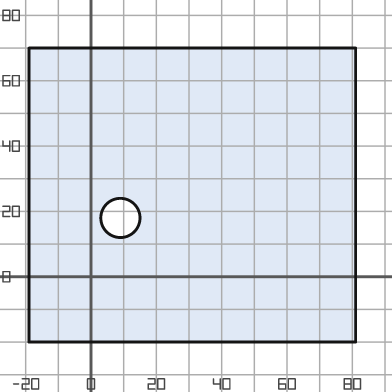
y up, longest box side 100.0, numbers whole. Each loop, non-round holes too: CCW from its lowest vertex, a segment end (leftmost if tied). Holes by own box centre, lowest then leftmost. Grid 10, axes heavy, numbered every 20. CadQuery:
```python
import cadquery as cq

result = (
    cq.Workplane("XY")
    .moveTo(-19.0, -20.0)
    .lineTo(81.0, -20.0)
    .lineTo(81.0, 70.0)
    .lineTo(-19.0, 70.0)
    .close()
    .moveTo(9.0, 18.0)
    .circle(6.0)
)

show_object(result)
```